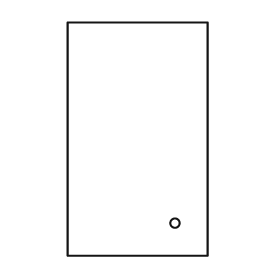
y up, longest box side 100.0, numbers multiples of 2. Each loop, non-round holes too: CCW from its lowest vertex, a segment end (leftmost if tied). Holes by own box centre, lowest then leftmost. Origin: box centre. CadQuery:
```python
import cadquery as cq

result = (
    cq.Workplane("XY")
    .moveTo(-30.0, -50.0)
    .lineTo(30.0, -50.0)
    .lineTo(30.0, 50.0)
    .lineTo(-30.0, 50.0)
    .close()
    .moveTo(16.0, -36.0)
    .circle(2.0)
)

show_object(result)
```